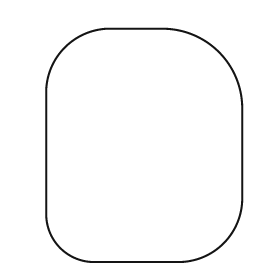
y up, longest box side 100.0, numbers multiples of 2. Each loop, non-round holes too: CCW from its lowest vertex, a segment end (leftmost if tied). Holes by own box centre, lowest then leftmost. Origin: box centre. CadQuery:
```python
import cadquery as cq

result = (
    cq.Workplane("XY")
    .moveTo(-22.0, -50.0)
    .lineTo(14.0, -50.0)
    .threePointArc((34.0, -42.0), (42.0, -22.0))
    .lineTo(42.0, 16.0)
    .threePointArc((32.0, 40.0), (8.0, 50.0))
    .lineTo(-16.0, 50.0)
    .threePointArc((-34.0, 42.0), (-42.0, 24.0))
    .lineTo(-42.0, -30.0)
    .threePointArc((-36.0, -44.0), (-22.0, -50.0))
    .close()
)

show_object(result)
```